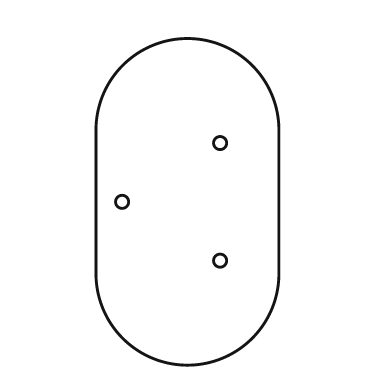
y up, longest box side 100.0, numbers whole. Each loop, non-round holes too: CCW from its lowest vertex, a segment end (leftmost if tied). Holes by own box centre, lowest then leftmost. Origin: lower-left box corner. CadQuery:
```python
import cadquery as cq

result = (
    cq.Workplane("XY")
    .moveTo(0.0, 28.0)
    .threePointArc((28.0, 0.0), (56.0, 28.0))
    .lineTo(56.0, 72.0)
    .threePointArc((28.0, 100.0), (0.0, 72.0))
    .close()
    .moveTo(38.0, 32.0)
    .circle(2.0)
    .moveTo(8.0, 50.0)
    .circle(2.0)
    .moveTo(38.0, 68.0)
    .circle(2.0)
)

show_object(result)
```